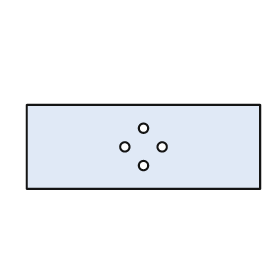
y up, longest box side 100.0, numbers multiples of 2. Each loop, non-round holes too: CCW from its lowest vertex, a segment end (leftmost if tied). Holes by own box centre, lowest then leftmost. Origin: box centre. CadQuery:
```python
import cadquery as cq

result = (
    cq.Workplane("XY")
    .moveTo(-50.0, -18.0)
    .lineTo(50.0, -18.0)
    .lineTo(50.0, 18.0)
    .lineTo(-50.0, 18.0)
    .close()
    .moveTo(0.0, -8.0)
    .circle(2.0)
    .moveTo(-8.0, 0.0)
    .circle(2.0)
    .moveTo(8.0, 0.0)
    .circle(2.0)
    .moveTo(0.0, 8.0)
    .circle(2.0)
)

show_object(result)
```